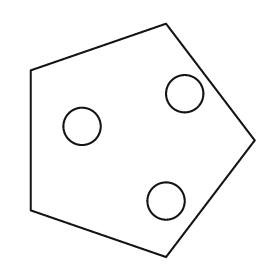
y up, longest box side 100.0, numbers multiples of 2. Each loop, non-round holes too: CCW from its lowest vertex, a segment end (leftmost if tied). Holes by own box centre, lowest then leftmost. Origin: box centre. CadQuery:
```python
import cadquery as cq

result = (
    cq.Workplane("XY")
    .moveTo(10.0, -50.0)
    .lineTo(48.0, 0.0)
    .lineTo(10.0, 50.0)
    .lineTo(-48.0, 30.0)
    .lineTo(-48.0, -30.0)
    .close()
    .moveTo(10.0, -26.0)
    .circle(8.0)
    .moveTo(-26.0, 6.0)
    .circle(8.0)
    .moveTo(18.0, 20.0)
    .circle(8.0)
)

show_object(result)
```